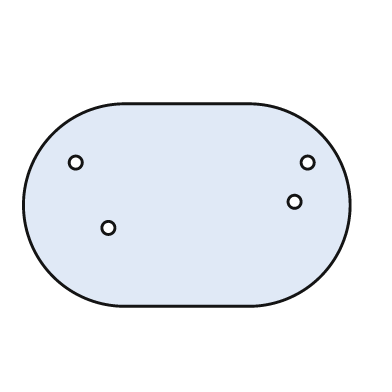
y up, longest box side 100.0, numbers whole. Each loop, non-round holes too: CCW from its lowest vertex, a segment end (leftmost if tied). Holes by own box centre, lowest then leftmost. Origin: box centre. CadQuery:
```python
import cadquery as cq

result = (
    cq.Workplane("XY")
    .moveTo(-19.0, -31.0)
    .lineTo(19.0, -31.0)
    .threePointArc((50.0, 0.0), (19.0, 31.0))
    .lineTo(-19.0, 31.0)
    .threePointArc((-50.0, 0.0), (-19.0, -31.0))
    .close()
    .moveTo(-24.0, -7.0)
    .circle(2.0)
    .moveTo(33.0, 1.0)
    .circle(2.0)
    .moveTo(-34.0, 13.0)
    .circle(2.0)
    .moveTo(37.0, 13.0)
    .circle(2.0)
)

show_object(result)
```